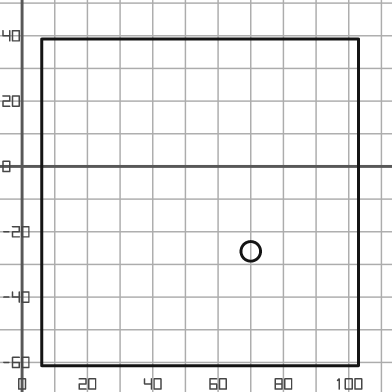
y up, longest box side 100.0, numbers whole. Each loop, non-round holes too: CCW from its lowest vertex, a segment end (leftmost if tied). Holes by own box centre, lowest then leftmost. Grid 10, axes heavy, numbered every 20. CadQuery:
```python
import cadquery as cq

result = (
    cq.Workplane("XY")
    .moveTo(6.0, -61.0)
    .lineTo(103.0, -61.0)
    .lineTo(103.0, 39.0)
    .lineTo(6.0, 39.0)
    .close()
    .moveTo(70.0, -26.0)
    .circle(3.0)
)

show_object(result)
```